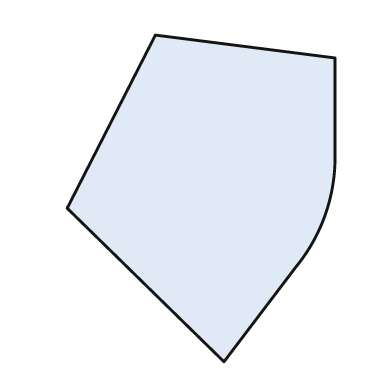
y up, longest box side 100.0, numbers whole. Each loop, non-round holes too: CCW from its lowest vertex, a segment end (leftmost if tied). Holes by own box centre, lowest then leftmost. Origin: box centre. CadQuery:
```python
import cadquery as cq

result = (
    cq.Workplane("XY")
    .moveTo(7.0, -50.0)
    .lineTo(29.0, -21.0)
    .threePointArc((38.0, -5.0), (41.0, 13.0))
    .lineTo(41.0, 43.0)
    .lineTo(-14.0, 50.0)
    .lineTo(-41.0, -3.0)
    .close()
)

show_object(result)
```